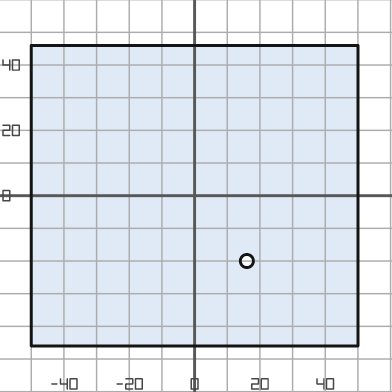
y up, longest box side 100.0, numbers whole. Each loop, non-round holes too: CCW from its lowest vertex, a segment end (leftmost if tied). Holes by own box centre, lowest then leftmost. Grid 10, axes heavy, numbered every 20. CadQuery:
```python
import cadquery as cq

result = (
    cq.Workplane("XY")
    .moveTo(-50.0, -46.0)
    .lineTo(50.0, -46.0)
    .lineTo(50.0, 46.0)
    .lineTo(-50.0, 46.0)
    .close()
    .moveTo(16.0, -20.0)
    .circle(2.0)
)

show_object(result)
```